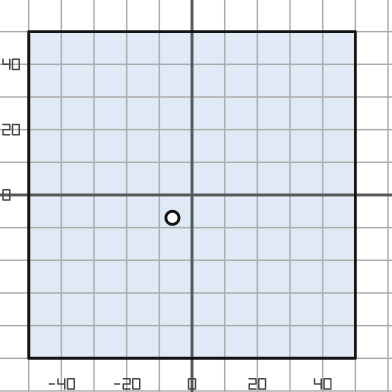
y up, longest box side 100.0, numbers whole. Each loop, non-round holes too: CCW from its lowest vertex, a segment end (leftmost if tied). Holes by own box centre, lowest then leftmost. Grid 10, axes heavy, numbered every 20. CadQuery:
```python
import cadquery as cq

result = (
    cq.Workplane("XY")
    .moveTo(-50.0, -50.0)
    .lineTo(50.0, -50.0)
    .lineTo(50.0, 50.0)
    .lineTo(-50.0, 50.0)
    .close()
    .moveTo(-6.0, -7.0)
    .circle(2.0)
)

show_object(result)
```